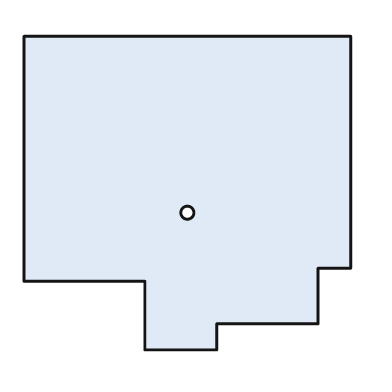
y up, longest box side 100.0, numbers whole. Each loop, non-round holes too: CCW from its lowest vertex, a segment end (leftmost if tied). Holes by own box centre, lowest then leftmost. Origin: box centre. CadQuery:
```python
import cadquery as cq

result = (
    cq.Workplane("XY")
    .moveTo(-13.0, -48.0)
    .lineTo(9.0, -48.0)
    .lineTo(9.0, -40.0)
    .lineTo(40.0, -40.0)
    .lineTo(40.0, -23.0)
    .lineTo(50.0, -23.0)
    .lineTo(50.0, 48.0)
    .lineTo(-50.0, 48.0)
    .lineTo(-50.0, -27.0)
    .lineTo(-13.0, -27.0)
    .close()
    .moveTo(0.0, -6.0)
    .circle(2.0)
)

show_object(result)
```